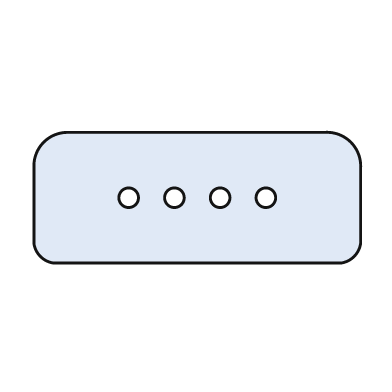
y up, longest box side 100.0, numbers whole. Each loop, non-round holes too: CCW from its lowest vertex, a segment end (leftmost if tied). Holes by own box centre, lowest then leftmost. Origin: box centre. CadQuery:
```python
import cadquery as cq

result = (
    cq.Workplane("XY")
    .moveTo(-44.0, -20.0)
    .lineTo(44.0, -20.0)
    .threePointArc((48.0, -18.0), (50.0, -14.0))
    .lineTo(50.0, 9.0)
    .threePointArc((47.0, 17.0), (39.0, 20.0))
    .lineTo(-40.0, 20.0)
    .threePointArc((-47.0, 17.0), (-50.0, 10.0))
    .lineTo(-50.0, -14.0)
    .threePointArc((-48.0, -18.0), (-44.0, -20.0))
    .close()
    .moveTo(-21.0, 0.0)
    .circle(3.0)
    .moveTo(-7.0, 0.0)
    .circle(3.0)
    .moveTo(7.0, 0.0)
    .circle(3.0)
    .moveTo(21.0, 0.0)
    .circle(3.0)
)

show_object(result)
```